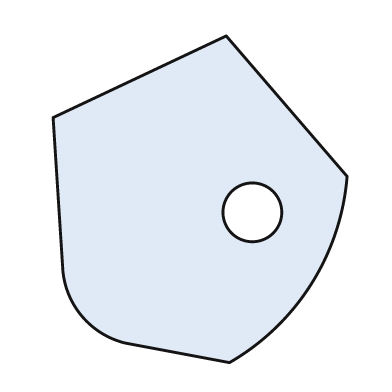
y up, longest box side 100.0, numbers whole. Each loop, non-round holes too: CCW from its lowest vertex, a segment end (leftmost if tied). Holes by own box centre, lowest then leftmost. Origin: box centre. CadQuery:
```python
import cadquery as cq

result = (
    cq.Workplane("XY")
    .moveTo(9.0, -50.0)
    .threePointArc((34.0, -26.0), (45.0, 7.0))
    .lineTo(8.0, 50.0)
    .lineTo(-45.0, 25.0)
    .lineTo(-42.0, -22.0)
    .threePointArc((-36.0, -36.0), (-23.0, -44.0))
    .close()
    .moveTo(16.0, -4.0)
    .circle(9.0)
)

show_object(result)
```